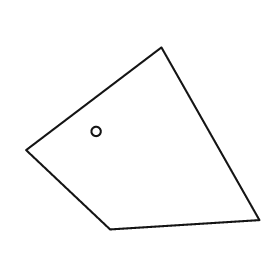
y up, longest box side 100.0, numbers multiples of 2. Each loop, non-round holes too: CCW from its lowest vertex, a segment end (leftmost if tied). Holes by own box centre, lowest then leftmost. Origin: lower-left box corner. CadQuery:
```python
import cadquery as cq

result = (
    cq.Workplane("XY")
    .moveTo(36.0, 0.0)
    .lineTo(100.0, 4.0)
    .lineTo(58.0, 78.0)
    .lineTo(0.0, 34.0)
    .close()
    .moveTo(30.0, 42.0)
    .circle(2.0)
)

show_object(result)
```